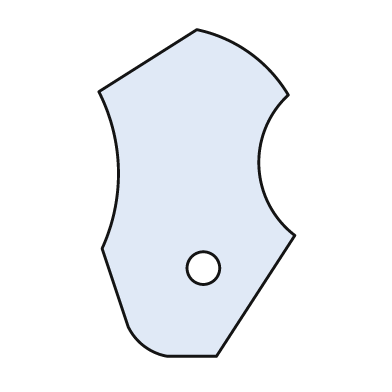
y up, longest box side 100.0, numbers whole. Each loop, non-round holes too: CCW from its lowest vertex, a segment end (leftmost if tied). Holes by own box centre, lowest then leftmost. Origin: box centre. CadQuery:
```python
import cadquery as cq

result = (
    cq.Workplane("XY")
    .moveTo(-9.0, -50.0)
    .lineTo(6.0, -50.0)
    .lineTo(30.0, -13.0)
    .threePointArc((19.0, 8.0), (28.0, 30.0))
    .threePointArc((16.0, 43.0), (0.0, 50.0))
    .lineTo(-30.0, 31.0)
    .threePointArc((-24.0, 7.0), (-29.0, -17.0))
    .lineTo(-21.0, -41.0)
    .threePointArc((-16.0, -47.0), (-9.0, -50.0))
    .close()
    .moveTo(2.0, -23.0)
    .circle(5.0)
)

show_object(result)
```